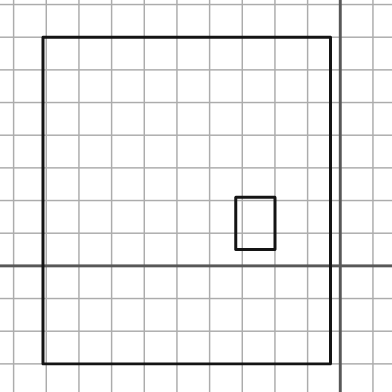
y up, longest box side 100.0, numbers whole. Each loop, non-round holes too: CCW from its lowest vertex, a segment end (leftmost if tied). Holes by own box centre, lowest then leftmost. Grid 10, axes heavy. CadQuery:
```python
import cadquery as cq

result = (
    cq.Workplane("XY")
    .moveTo(-91.0, -30.0)
    .lineTo(-3.0, -30.0)
    .lineTo(-3.0, 70.0)
    .lineTo(-91.0, 70.0)
    .close()
    .moveTo(-32.0, 5.0)
    .lineTo(-20.0, 5.0)
    .lineTo(-20.0, 21.0)
    .lineTo(-32.0, 21.0)
    .close()
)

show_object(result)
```